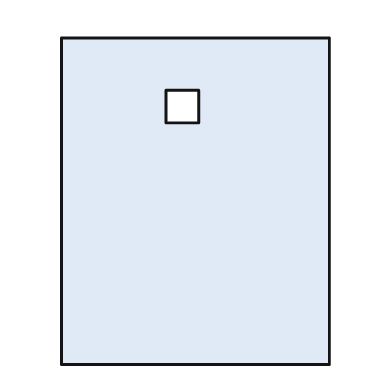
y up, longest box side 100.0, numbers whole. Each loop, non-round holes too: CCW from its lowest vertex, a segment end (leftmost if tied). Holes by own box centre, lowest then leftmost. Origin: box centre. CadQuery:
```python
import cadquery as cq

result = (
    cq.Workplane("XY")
    .moveTo(-41.0, -50.0)
    .lineTo(41.0, -50.0)
    .lineTo(41.0, 50.0)
    .lineTo(-41.0, 50.0)
    .close()
    .moveTo(-9.0, 24.0)
    .lineTo(1.0, 24.0)
    .lineTo(1.0, 34.0)
    .lineTo(-9.0, 34.0)
    .close()
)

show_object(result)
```